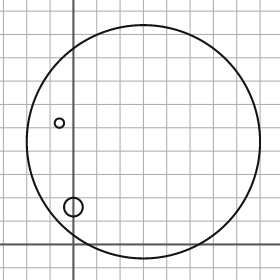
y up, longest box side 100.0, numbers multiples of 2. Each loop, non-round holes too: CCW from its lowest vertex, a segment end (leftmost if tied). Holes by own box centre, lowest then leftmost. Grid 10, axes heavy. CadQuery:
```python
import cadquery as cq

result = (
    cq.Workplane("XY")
    .moveTo(30.0, 44.0)
    .circle(50.0)
    .moveTo(0.0, 16.0)
    .circle(4.0)
    .moveTo(-6.0, 52.0)
    .circle(2.0)
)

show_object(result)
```